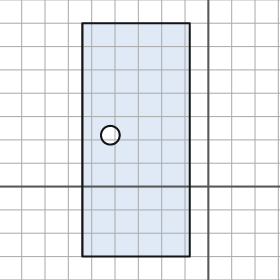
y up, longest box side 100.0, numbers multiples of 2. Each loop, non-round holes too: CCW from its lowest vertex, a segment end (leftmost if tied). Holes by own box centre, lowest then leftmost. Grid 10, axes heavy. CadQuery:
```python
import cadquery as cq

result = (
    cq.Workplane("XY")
    .moveTo(-54.0, -30.0)
    .lineTo(-8.0, -30.0)
    .lineTo(-8.0, 70.0)
    .lineTo(-54.0, 70.0)
    .close()
    .moveTo(-42.0, 22.0)
    .circle(4.0)
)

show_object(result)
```